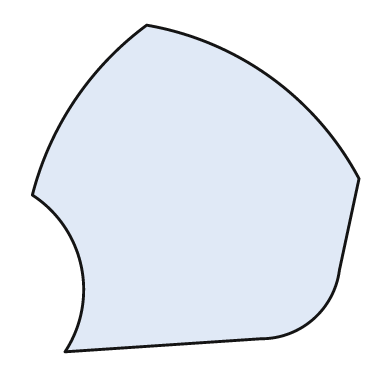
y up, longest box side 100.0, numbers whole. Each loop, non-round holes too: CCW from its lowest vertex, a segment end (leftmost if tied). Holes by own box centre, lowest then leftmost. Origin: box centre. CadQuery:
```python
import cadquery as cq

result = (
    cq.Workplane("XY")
    .moveTo(-40.0, -50.0)
    .lineTo(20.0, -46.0)
    .threePointArc((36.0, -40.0), (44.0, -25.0))
    .lineTo(50.0, 3.0)
    .threePointArc((23.0, 34.0), (-15.0, 50.0))
    .threePointArc((-37.0, 27.0), (-50.0, -2.0))
    .threePointArc((-35.0, -24.0), (-40.0, -50.0))
    .close()
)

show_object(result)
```